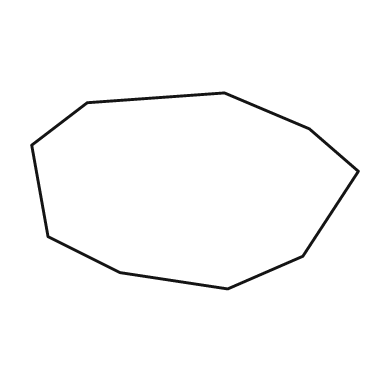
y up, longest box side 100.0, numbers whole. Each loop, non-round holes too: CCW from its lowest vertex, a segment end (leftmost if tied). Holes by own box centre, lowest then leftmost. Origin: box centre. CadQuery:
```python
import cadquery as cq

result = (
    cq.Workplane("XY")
    .moveTo(10.0, -30.0)
    .lineTo(33.0, -20.0)
    .lineTo(50.0, 6.0)
    .lineTo(35.0, 19.0)
    .lineTo(9.0, 30.0)
    .lineTo(-33.0, 27.0)
    .lineTo(-50.0, 14.0)
    .lineTo(-45.0, -14.0)
    .lineTo(-23.0, -25.0)
    .close()
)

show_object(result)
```